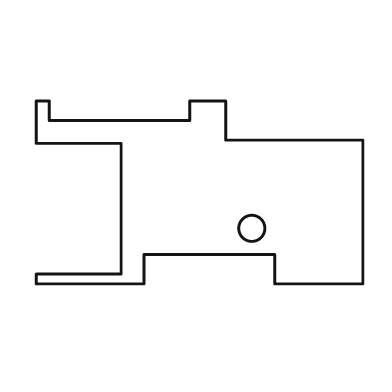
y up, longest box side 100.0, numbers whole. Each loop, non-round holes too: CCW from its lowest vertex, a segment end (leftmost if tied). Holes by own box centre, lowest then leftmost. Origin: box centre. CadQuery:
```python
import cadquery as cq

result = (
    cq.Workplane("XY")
    .moveTo(-50.0, -28.0)
    .lineTo(-17.0, -28.0)
    .lineTo(-17.0, -19.0)
    .lineTo(23.0, -19.0)
    .lineTo(23.0, -28.0)
    .lineTo(50.0, -28.0)
    .lineTo(50.0, 16.0)
    .lineTo(8.0, 16.0)
    .lineTo(8.0, 28.0)
    .lineTo(-3.0, 28.0)
    .lineTo(-3.0, 22.0)
    .lineTo(-46.0, 22.0)
    .lineTo(-46.0, 28.0)
    .lineTo(-50.0, 28.0)
    .lineTo(-50.0, 15.0)
    .lineTo(-24.0, 15.0)
    .lineTo(-24.0, -25.0)
    .lineTo(-50.0, -25.0)
    .close()
    .moveTo(16.0, -11.0)
    .circle(4.0)
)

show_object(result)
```